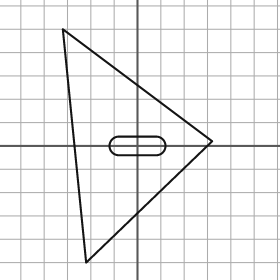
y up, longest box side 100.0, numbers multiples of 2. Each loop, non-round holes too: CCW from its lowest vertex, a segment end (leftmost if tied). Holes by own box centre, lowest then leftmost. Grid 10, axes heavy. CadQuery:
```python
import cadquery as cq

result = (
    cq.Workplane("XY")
    .moveTo(-22.0, -50.0)
    .lineTo(32.0, 2.0)
    .lineTo(-32.0, 50.0)
    .close()
    .moveTo(-8.0, -4.0)
    .lineTo(8.0, -4.0)
    .threePointArc((12.0, 0.0), (8.0, 4.0))
    .lineTo(-8.0, 4.0)
    .threePointArc((-12.0, 0.0), (-8.0, -4.0))
    .close()
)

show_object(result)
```